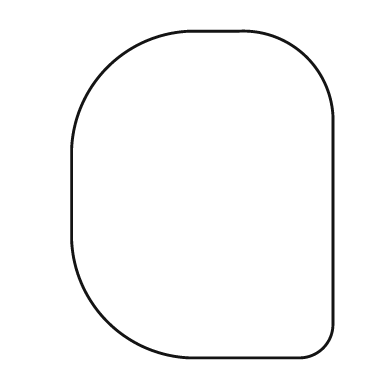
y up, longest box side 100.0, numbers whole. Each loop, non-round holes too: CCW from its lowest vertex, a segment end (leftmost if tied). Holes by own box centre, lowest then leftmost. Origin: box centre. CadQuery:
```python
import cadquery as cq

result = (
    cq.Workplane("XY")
    .moveTo(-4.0, -50.0)
    .lineTo(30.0, -50.0)
    .threePointArc((37.0, -47.0), (40.0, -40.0))
    .lineTo(40.0, 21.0)
    .threePointArc((32.0, 42.0), (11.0, 50.0))
    .lineTo(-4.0, 50.0)
    .threePointArc((-29.0, 39.0), (-40.0, 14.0))
    .lineTo(-40.0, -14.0)
    .threePointArc((-29.0, -39.0), (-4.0, -50.0))
    .close()
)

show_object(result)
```